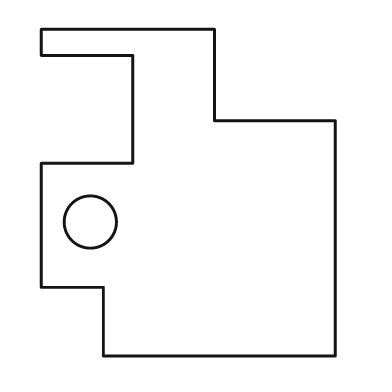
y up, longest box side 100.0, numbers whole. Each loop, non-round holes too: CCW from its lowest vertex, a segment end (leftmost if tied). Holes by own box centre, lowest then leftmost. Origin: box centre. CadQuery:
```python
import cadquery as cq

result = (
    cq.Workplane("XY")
    .moveTo(-26.0, -50.0)
    .lineTo(45.0, -50.0)
    .lineTo(45.0, 22.0)
    .lineTo(8.0, 22.0)
    .lineTo(8.0, 50.0)
    .lineTo(-45.0, 50.0)
    .lineTo(-45.0, 42.0)
    .lineTo(-17.0, 42.0)
    .lineTo(-17.0, 9.0)
    .lineTo(-45.0, 9.0)
    .lineTo(-45.0, -29.0)
    .lineTo(-26.0, -29.0)
    .close()
    .moveTo(-30.0, -9.0)
    .circle(8.0)
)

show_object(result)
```